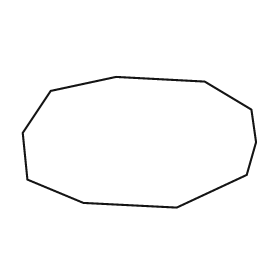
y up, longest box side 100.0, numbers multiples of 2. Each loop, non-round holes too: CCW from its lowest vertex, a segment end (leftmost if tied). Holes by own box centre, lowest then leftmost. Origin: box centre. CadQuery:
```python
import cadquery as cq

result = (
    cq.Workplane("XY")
    .moveTo(16.0, -28.0)
    .lineTo(46.0, -14.0)
    .lineTo(50.0, 0.0)
    .lineTo(48.0, 14.0)
    .lineTo(28.0, 26.0)
    .lineTo(-10.0, 28.0)
    .lineTo(-38.0, 22.0)
    .lineTo(-50.0, 4.0)
    .lineTo(-48.0, -16.0)
    .lineTo(-24.0, -26.0)
    .close()
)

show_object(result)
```